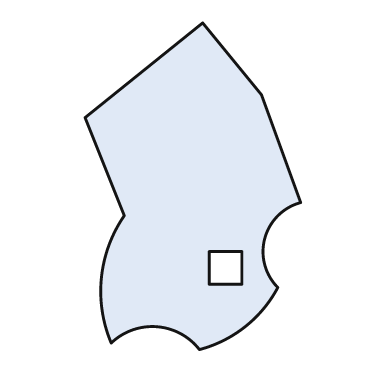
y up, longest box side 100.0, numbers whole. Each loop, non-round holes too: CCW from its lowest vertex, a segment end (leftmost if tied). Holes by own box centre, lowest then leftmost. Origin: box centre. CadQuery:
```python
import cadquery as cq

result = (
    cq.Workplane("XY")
    .moveTo(2.0, -50.0)
    .threePointArc((16.0, -43.0), (26.0, -31.0))
    .threePointArc((22.0, -16.0), (33.0, -5.0))
    .lineTo(21.0, 28.0)
    .lineTo(3.0, 50.0)
    .lineTo(-33.0, 21.0)
    .lineTo(-21.0, -9.0)
    .threePointArc((-28.0, -28.0), (-25.0, -48.0))
    .threePointArc((-11.0, -43.0), (2.0, -50.0))
    .close()
    .moveTo(5.0, -30.0)
    .lineTo(15.0, -30.0)
    .lineTo(15.0, -20.0)
    .lineTo(5.0, -20.0)
    .close()
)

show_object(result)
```